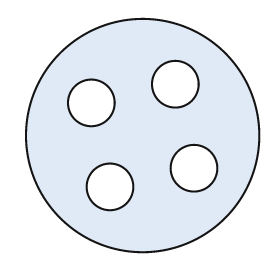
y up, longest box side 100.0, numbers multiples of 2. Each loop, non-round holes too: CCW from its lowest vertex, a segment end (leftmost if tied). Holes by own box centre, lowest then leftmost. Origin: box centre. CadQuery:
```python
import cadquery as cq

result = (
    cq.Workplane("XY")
    .moveTo(0.0, 0.0)
    .circle(50.0)
    .moveTo(-14.0, -22.0)
    .circle(10.0)
    .moveTo(22.0, -14.0)
    .circle(10.0)
    .moveTo(-22.0, 14.0)
    .circle(10.0)
    .moveTo(14.0, 22.0)
    .circle(10.0)
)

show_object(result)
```